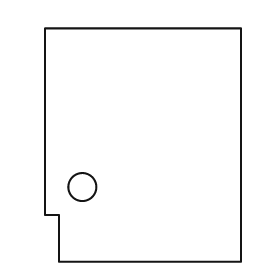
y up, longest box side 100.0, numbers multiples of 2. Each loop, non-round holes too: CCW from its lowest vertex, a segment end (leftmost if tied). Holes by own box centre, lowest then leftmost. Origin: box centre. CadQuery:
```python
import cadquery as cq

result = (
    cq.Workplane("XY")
    .moveTo(-36.0, -50.0)
    .lineTo(42.0, -50.0)
    .lineTo(42.0, 50.0)
    .lineTo(-42.0, 50.0)
    .lineTo(-42.0, -30.0)
    .lineTo(-36.0, -30.0)
    .close()
    .moveTo(-26.0, -18.0)
    .circle(6.0)
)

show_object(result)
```